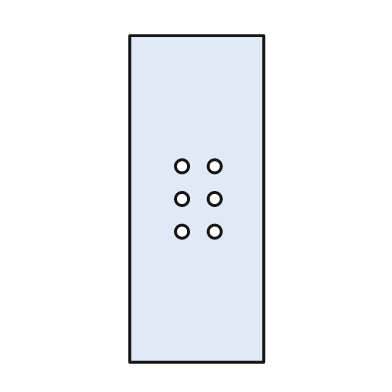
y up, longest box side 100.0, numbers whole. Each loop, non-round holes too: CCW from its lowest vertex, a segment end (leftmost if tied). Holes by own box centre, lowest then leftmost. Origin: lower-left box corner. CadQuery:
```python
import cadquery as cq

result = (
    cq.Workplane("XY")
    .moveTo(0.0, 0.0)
    .lineTo(41.0, 0.0)
    .lineTo(41.0, 100.0)
    .lineTo(0.0, 100.0)
    .close()
    .moveTo(16.0, 40.0)
    .circle(2.0)
    .moveTo(26.0, 40.0)
    .circle(2.0)
    .moveTo(16.0, 50.0)
    .circle(2.0)
    .moveTo(26.0, 50.0)
    .circle(2.0)
    .moveTo(16.0, 60.0)
    .circle(2.0)
    .moveTo(26.0, 60.0)
    .circle(2.0)
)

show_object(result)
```